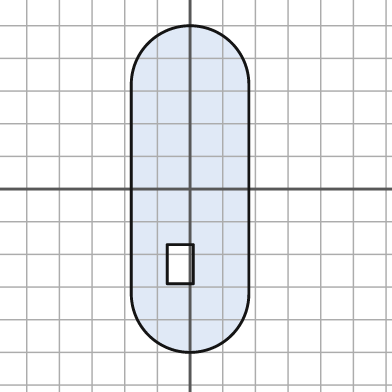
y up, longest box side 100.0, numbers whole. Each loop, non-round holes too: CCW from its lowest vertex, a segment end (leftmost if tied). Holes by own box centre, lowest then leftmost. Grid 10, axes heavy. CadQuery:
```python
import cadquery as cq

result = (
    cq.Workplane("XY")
    .moveTo(-18.0, -32.0)
    .threePointArc((0.0, -50.0), (18.0, -32.0))
    .lineTo(18.0, 32.0)
    .threePointArc((0.0, 50.0), (-18.0, 32.0))
    .close()
    .moveTo(-7.0, -29.0)
    .lineTo(1.0, -29.0)
    .lineTo(1.0, -17.0)
    .lineTo(-7.0, -17.0)
    .close()
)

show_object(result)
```